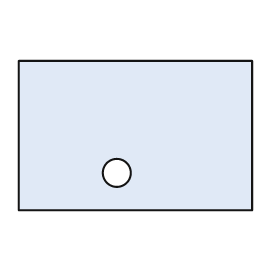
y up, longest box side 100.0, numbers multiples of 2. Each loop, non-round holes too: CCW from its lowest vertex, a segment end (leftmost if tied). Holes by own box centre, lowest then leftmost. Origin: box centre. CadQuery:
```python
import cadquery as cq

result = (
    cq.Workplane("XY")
    .moveTo(-50.0, -32.0)
    .lineTo(50.0, -32.0)
    .lineTo(50.0, 32.0)
    .lineTo(-50.0, 32.0)
    .close()
    .moveTo(-8.0, -16.0)
    .circle(6.0)
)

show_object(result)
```